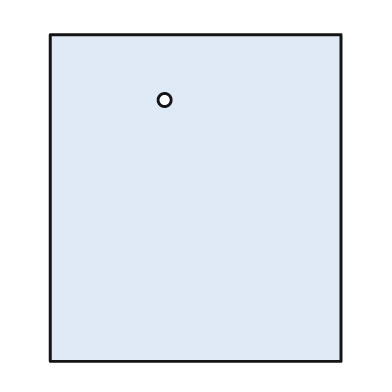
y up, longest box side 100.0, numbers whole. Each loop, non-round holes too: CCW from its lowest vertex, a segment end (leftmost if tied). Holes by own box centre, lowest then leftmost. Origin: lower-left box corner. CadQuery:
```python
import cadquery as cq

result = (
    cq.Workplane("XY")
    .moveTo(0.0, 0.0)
    .lineTo(89.0, 0.0)
    .lineTo(89.0, 100.0)
    .lineTo(0.0, 100.0)
    .close()
    .moveTo(35.0, 80.0)
    .circle(2.0)
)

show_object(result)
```